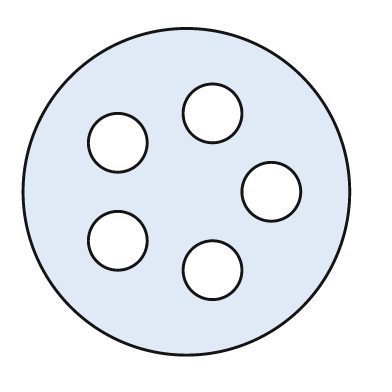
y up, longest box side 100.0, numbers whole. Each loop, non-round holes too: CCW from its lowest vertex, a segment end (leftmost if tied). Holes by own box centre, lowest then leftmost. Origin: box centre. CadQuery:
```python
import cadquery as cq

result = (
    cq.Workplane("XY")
    .moveTo(0.0, 0.0)
    .circle(50.0)
    .moveTo(8.0, -24.0)
    .circle(9.0)
    .moveTo(-21.0, -15.0)
    .circle(9.0)
    .moveTo(26.0, 0.0)
    .circle(9.0)
    .moveTo(-21.0, 15.0)
    .circle(9.0)
    .moveTo(8.0, 24.0)
    .circle(9.0)
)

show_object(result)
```